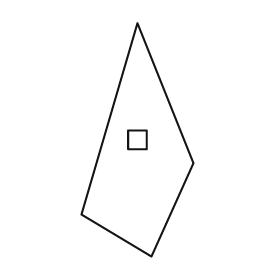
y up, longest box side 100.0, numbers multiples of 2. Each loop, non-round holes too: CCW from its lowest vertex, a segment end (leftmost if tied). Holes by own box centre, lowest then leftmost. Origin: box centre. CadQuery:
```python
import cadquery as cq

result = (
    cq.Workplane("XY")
    .moveTo(6.0, -50.0)
    .lineTo(24.0, -10.0)
    .lineTo(0.0, 50.0)
    .lineTo(-24.0, -32.0)
    .close()
    .moveTo(-4.0, -4.0)
    .lineTo(4.0, -4.0)
    .lineTo(4.0, 4.0)
    .lineTo(-4.0, 4.0)
    .close()
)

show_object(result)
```